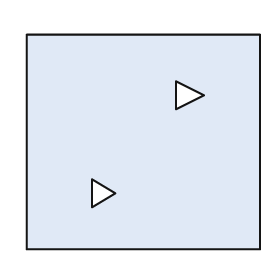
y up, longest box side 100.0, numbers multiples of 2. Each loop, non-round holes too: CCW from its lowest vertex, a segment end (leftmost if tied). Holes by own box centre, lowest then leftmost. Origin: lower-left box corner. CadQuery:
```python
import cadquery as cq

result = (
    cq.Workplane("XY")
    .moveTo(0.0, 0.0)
    .lineTo(100.0, 0.0)
    .lineTo(100.0, 92.0)
    .lineTo(0.0, 92.0)
    .close()
    .moveTo(28.0, 18.0)
    .lineTo(38.0, 24.0)
    .lineTo(28.0, 30.0)
    .close()
    .moveTo(64.0, 60.0)
    .lineTo(76.0, 66.0)
    .lineTo(64.0, 72.0)
    .close()
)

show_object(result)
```